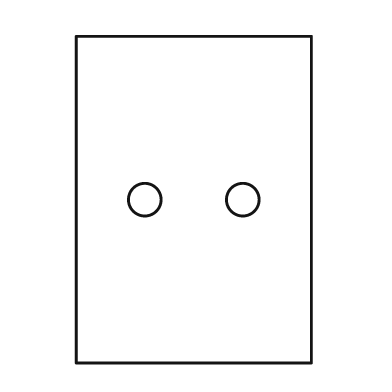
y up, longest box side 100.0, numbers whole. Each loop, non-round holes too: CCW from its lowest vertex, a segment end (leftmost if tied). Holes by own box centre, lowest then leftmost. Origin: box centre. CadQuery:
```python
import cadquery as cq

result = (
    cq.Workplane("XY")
    .moveTo(-36.0, -50.0)
    .lineTo(36.0, -50.0)
    .lineTo(36.0, 50.0)
    .lineTo(-36.0, 50.0)
    .close()
    .moveTo(-15.0, 0.0)
    .circle(5.0)
    .moveTo(15.0, 0.0)
    .circle(5.0)
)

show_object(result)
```